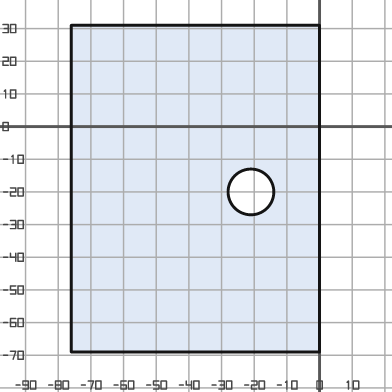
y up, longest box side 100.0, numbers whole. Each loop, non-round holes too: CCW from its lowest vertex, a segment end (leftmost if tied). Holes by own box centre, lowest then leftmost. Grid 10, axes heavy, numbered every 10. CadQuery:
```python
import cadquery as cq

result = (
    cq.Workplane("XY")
    .moveTo(-76.0, -69.0)
    .lineTo(0.0, -69.0)
    .lineTo(0.0, 31.0)
    .lineTo(-76.0, 31.0)
    .close()
    .moveTo(-21.0, -20.0)
    .circle(7.0)
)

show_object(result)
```